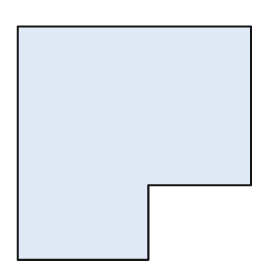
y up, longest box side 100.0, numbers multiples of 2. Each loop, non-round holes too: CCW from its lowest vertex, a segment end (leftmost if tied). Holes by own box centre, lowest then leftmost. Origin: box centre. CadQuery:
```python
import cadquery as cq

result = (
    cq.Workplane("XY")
    .moveTo(-50.0, -50.0)
    .lineTo(6.0, -50.0)
    .lineTo(6.0, -18.0)
    .lineTo(50.0, -18.0)
    .lineTo(50.0, 50.0)
    .lineTo(-50.0, 50.0)
    .close()
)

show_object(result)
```